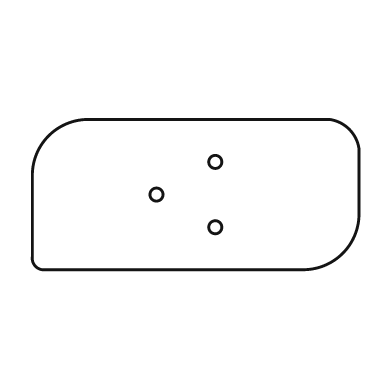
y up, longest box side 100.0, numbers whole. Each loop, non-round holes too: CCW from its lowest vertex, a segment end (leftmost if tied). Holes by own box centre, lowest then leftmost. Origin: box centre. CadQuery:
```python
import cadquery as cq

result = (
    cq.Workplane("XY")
    .moveTo(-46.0, -23.0)
    .lineTo(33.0, -23.0)
    .threePointArc((45.0, -18.0), (50.0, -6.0))
    .lineTo(50.0, 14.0)
    .threePointArc((47.0, 20.0), (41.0, 23.0))
    .lineTo(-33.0, 23.0)
    .threePointArc((-45.0, 18.0), (-50.0, 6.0))
    .lineTo(-50.0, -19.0)
    .threePointArc((-49.0, -22.0), (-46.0, -23.0))
    .close()
    .moveTo(6.0, -10.0)
    .circle(2.0)
    .moveTo(-12.0, 0.0)
    .circle(2.0)
    .moveTo(6.0, 10.0)
    .circle(2.0)
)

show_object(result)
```